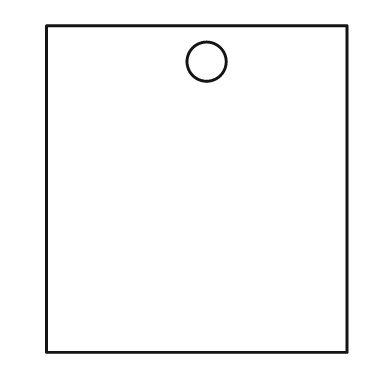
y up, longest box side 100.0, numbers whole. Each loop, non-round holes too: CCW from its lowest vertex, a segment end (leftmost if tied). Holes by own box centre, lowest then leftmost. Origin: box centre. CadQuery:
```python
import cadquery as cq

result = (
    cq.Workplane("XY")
    .moveTo(-46.0, -50.0)
    .lineTo(46.0, -50.0)
    .lineTo(46.0, 50.0)
    .lineTo(-46.0, 50.0)
    .close()
    .moveTo(3.0, 39.0)
    .circle(6.0)
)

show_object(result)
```